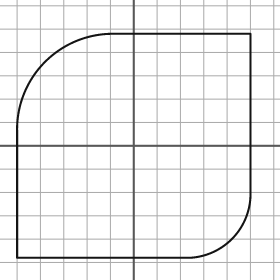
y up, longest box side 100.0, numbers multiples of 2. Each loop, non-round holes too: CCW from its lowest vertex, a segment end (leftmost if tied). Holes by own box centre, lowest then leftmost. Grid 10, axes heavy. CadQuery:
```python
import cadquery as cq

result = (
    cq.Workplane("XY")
    .moveTo(-50.0, -48.0)
    .lineTo(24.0, -48.0)
    .threePointArc((42.0, -40.0), (50.0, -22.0))
    .lineTo(50.0, 48.0)
    .lineTo(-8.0, 48.0)
    .threePointArc((-38.0, 36.0), (-50.0, 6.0))
    .close()
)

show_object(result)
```